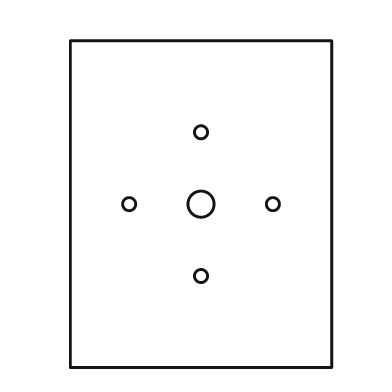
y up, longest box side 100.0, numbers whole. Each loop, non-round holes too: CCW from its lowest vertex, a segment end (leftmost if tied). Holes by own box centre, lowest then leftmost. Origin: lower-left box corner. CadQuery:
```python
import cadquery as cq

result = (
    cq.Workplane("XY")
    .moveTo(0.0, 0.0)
    .lineTo(80.0, 0.0)
    .lineTo(80.0, 100.0)
    .lineTo(0.0, 100.0)
    .close()
    .moveTo(40.0, 28.0)
    .circle(2.0)
    .moveTo(18.0, 50.0)
    .circle(2.0)
    .moveTo(40.0, 50.0)
    .circle(4.0)
    .moveTo(62.0, 50.0)
    .circle(2.0)
    .moveTo(40.0, 72.0)
    .circle(2.0)
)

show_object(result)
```